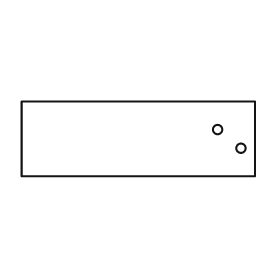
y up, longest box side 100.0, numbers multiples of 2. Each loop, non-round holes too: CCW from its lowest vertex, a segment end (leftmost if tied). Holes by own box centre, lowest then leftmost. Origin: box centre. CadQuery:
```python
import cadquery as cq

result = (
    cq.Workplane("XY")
    .moveTo(-50.0, -16.0)
    .lineTo(50.0, -16.0)
    .lineTo(50.0, 16.0)
    .lineTo(-50.0, 16.0)
    .close()
    .moveTo(44.0, -4.0)
    .circle(2.0)
    .moveTo(34.0, 4.0)
    .circle(2.0)
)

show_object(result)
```